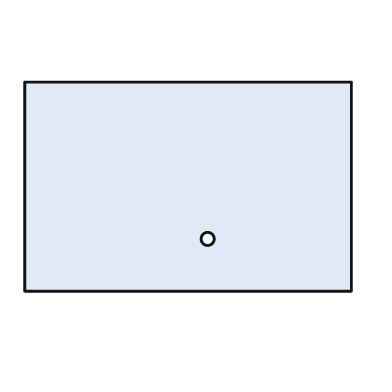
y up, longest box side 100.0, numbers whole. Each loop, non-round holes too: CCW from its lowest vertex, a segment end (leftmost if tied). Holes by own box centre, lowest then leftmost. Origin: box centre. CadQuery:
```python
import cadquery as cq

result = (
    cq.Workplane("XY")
    .moveTo(-50.0, -32.0)
    .lineTo(50.0, -32.0)
    .lineTo(50.0, 32.0)
    .lineTo(-50.0, 32.0)
    .close()
    .moveTo(6.0, -16.0)
    .circle(2.0)
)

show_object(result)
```